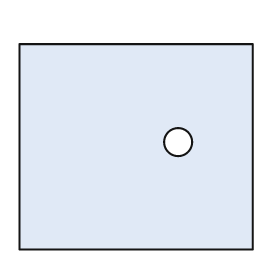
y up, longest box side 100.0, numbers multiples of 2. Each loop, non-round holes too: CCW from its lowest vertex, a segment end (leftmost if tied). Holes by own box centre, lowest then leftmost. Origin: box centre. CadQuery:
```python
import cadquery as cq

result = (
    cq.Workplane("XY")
    .moveTo(-50.0, -44.0)
    .lineTo(50.0, -44.0)
    .lineTo(50.0, 44.0)
    .lineTo(-50.0, 44.0)
    .close()
    .moveTo(18.0, 2.0)
    .circle(6.0)
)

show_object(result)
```